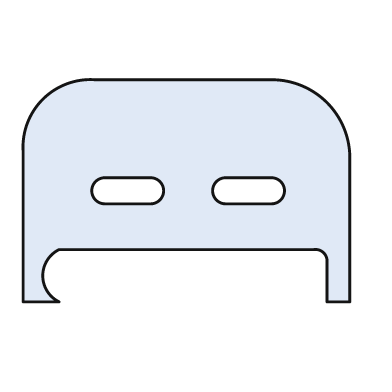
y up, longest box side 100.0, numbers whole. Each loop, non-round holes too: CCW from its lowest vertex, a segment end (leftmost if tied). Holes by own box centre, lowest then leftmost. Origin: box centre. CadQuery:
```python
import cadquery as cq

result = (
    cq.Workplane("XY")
    .moveTo(-50.0, -34.0)
    .lineTo(-39.0, -34.0)
    .threePointArc((-44.0, -26.0), (-39.0, -18.0))
    .lineTo(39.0, -18.0)
    .threePointArc((42.0, -19.0), (43.0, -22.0))
    .lineTo(43.0, -34.0)
    .lineTo(50.0, -34.0)
    .lineTo(50.0, 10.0)
    .threePointArc((43.0, 27.0), (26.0, 34.0))
    .lineTo(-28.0, 34.0)
    .threePointArc((-44.0, 28.0), (-50.0, 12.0))
    .close()
    .moveTo(-25.0, -4.0)
    .lineTo(-11.0, -4.0)
    .threePointArc((-7.0, 0.0), (-11.0, 4.0))
    .lineTo(-25.0, 4.0)
    .threePointArc((-29.0, 0.0), (-25.0, -4.0))
    .close()
    .moveTo(12.0, -4.0)
    .lineTo(26.0, -4.0)
    .threePointArc((30.0, 0.0), (26.0, 4.0))
    .lineTo(12.0, 4.0)
    .threePointArc((8.0, 0.0), (12.0, -4.0))
    .close()
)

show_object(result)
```